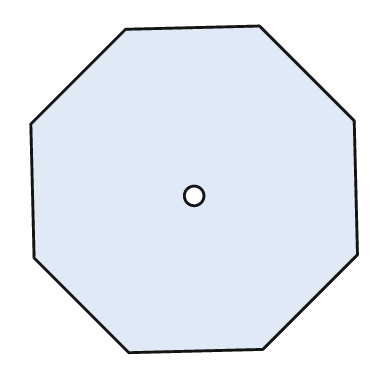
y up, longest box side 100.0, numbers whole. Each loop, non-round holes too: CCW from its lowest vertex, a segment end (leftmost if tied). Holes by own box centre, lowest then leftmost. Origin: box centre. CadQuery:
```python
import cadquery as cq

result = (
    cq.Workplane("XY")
    .moveTo(-20.0, -50.0)
    .lineTo(21.0, -49.0)
    .lineTo(50.0, -20.0)
    .lineTo(49.0, 21.0)
    .lineTo(20.0, 50.0)
    .lineTo(-21.0, 49.0)
    .lineTo(-50.0, 20.0)
    .lineTo(-49.0, -21.0)
    .close()
    .moveTo(0.0, -2.0)
    .circle(3.0)
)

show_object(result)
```